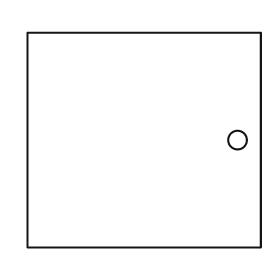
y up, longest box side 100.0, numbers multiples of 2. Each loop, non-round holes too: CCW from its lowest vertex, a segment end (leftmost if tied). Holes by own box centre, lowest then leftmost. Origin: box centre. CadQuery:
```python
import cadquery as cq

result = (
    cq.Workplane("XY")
    .moveTo(-50.0, -46.0)
    .lineTo(50.0, -46.0)
    .lineTo(50.0, 46.0)
    .lineTo(-50.0, 46.0)
    .close()
    .moveTo(40.0, 0.0)
    .circle(4.0)
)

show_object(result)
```